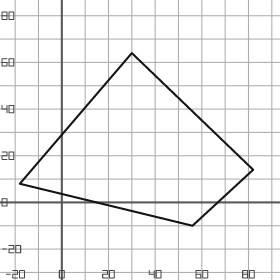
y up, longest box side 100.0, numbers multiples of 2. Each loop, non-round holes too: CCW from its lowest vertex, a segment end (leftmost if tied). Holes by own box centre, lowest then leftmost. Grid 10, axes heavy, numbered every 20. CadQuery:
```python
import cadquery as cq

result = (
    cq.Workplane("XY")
    .moveTo(56.0, -10.0)
    .lineTo(82.0, 14.0)
    .lineTo(30.0, 64.0)
    .lineTo(-18.0, 8.0)
    .close()
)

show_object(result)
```